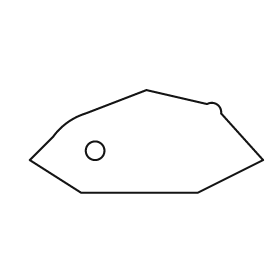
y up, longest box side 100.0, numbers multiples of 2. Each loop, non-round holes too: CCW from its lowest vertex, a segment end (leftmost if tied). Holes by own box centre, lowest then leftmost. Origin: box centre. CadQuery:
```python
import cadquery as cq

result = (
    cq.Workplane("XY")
    .moveTo(-28.0, -22.0)
    .lineTo(22.0, -22.0)
    .lineTo(50.0, -8.0)
    .lineTo(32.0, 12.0)
    .threePointArc((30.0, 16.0), (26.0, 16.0))
    .lineTo(0.0, 22.0)
    .lineTo(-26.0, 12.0)
    .threePointArc((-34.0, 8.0), (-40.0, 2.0))
    .lineTo(-50.0, -8.0)
    .close()
    .moveTo(-22.0, -4.0)
    .circle(4.0)
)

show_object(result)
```